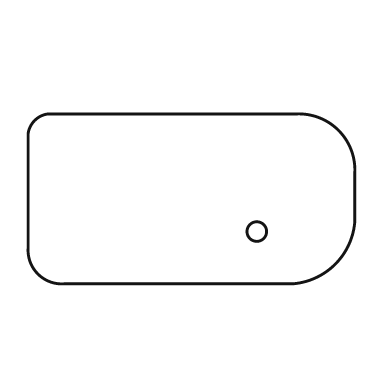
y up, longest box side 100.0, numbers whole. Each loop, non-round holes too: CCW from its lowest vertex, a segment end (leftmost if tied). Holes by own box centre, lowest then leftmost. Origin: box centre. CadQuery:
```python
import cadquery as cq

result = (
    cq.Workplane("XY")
    .moveTo(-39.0, -26.0)
    .lineTo(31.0, -26.0)
    .threePointArc((44.0, -20.0), (50.0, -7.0))
    .lineTo(50.0, 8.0)
    .threePointArc((45.0, 21.0), (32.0, 26.0))
    .lineTo(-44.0, 26.0)
    .threePointArc((-48.0, 24.0), (-50.0, 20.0))
    .lineTo(-50.0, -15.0)
    .threePointArc((-47.0, -23.0), (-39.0, -26.0))
    .close()
    .moveTo(20.0, -10.0)
    .circle(3.0)
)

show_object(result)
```